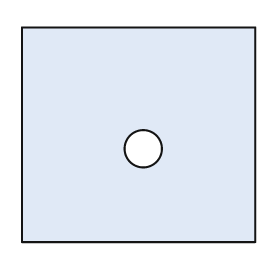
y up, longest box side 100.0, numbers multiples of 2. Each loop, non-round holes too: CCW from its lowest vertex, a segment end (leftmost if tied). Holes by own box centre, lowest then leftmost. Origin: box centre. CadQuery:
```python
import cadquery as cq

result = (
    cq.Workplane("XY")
    .moveTo(-50.0, -46.0)
    .lineTo(50.0, -46.0)
    .lineTo(50.0, 46.0)
    .lineTo(-50.0, 46.0)
    .close()
    .moveTo(2.0, -6.0)
    .circle(8.0)
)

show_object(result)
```